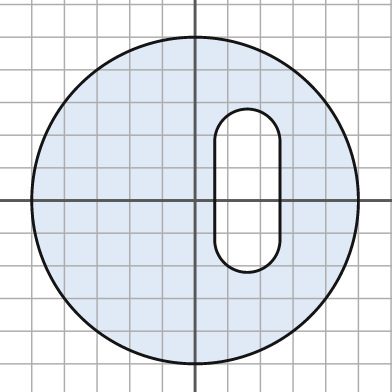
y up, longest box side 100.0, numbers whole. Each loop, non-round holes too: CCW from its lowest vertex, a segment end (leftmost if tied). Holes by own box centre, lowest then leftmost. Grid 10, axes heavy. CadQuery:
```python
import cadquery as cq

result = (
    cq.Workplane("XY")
    .moveTo(0.0, 0.0)
    .circle(50.0)
    .moveTo(6.0, -12.0)
    .threePointArc((16.0, -22.0), (26.0, -12.0))
    .lineTo(26.0, 18.0)
    .threePointArc((16.0, 28.0), (6.0, 18.0))
    .close()
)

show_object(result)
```